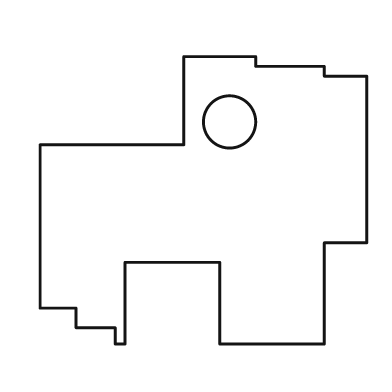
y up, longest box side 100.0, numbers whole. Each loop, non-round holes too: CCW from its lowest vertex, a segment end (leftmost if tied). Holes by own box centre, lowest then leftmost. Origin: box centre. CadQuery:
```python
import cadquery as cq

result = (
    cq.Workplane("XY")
    .moveTo(-27.0, -44.0)
    .lineTo(-24.0, -44.0)
    .lineTo(-24.0, -19.0)
    .lineTo(5.0, -19.0)
    .lineTo(5.0, -44.0)
    .lineTo(37.0, -44.0)
    .lineTo(37.0, -13.0)
    .lineTo(50.0, -13.0)
    .lineTo(50.0, 38.0)
    .lineTo(37.0, 38.0)
    .lineTo(37.0, 41.0)
    .lineTo(16.0, 41.0)
    .lineTo(16.0, 44.0)
    .lineTo(-6.0, 44.0)
    .lineTo(-6.0, 17.0)
    .lineTo(-50.0, 17.0)
    .lineTo(-50.0, -33.0)
    .lineTo(-39.0, -33.0)
    .lineTo(-39.0, -39.0)
    .lineTo(-27.0, -39.0)
    .close()
    .moveTo(8.0, 24.0)
    .circle(8.0)
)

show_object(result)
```